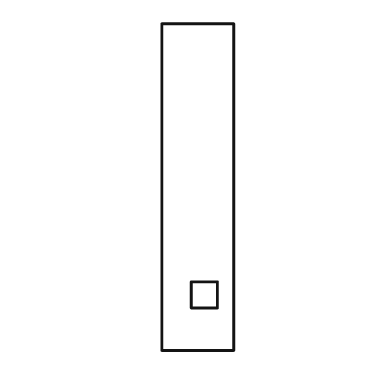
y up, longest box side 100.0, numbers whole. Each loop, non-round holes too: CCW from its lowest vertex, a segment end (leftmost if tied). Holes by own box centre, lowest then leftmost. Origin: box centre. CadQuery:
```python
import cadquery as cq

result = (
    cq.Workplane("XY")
    .moveTo(-11.0, -50.0)
    .lineTo(11.0, -50.0)
    .lineTo(11.0, 50.0)
    .lineTo(-11.0, 50.0)
    .close()
    .moveTo(-2.0, -37.0)
    .lineTo(6.0, -37.0)
    .lineTo(6.0, -29.0)
    .lineTo(-2.0, -29.0)
    .close()
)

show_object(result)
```